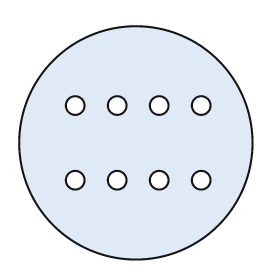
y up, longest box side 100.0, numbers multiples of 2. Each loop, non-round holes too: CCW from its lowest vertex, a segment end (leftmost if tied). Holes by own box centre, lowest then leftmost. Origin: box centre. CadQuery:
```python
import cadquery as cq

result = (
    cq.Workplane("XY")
    .moveTo(0.0, 0.0)
    .circle(50.0)
    .moveTo(-26.0, -16.0)
    .circle(4.0)
    .moveTo(-8.0, -16.0)
    .circle(4.0)
    .moveTo(10.0, -16.0)
    .circle(4.0)
    .moveTo(28.0, -16.0)
    .circle(4.0)
    .moveTo(-26.0, 16.0)
    .circle(4.0)
    .moveTo(-8.0, 16.0)
    .circle(4.0)
    .moveTo(10.0, 16.0)
    .circle(4.0)
    .moveTo(28.0, 16.0)
    .circle(4.0)
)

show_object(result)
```